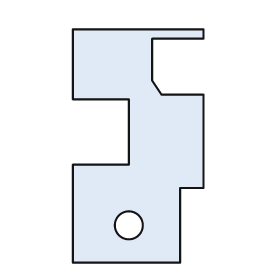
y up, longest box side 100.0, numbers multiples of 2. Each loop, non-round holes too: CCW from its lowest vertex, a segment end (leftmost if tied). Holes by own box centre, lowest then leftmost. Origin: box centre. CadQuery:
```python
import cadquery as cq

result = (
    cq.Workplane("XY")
    .moveTo(-28.0, -50.0)
    .lineTo(18.0, -50.0)
    .lineTo(18.0, -18.0)
    .lineTo(28.0, -18.0)
    .lineTo(28.0, 22.0)
    .lineTo(10.0, 22.0)
    .lineTo(6.0, 28.0)
    .lineTo(6.0, 46.0)
    .lineTo(28.0, 46.0)
    .lineTo(28.0, 50.0)
    .lineTo(-28.0, 50.0)
    .lineTo(-28.0, 20.0)
    .lineTo(-4.0, 20.0)
    .lineTo(-4.0, -8.0)
    .lineTo(-28.0, -8.0)
    .close()
    .moveTo(-4.0, -34.0)
    .circle(6.0)
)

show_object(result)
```